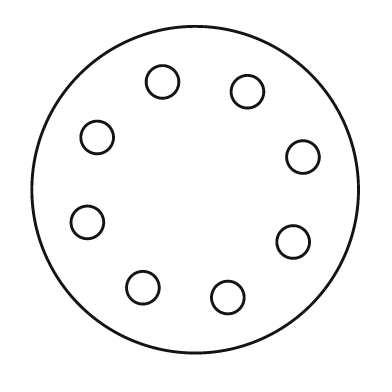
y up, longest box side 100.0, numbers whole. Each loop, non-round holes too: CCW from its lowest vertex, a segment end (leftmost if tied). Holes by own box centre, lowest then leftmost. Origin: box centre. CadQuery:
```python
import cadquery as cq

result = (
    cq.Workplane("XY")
    .moveTo(0.0, 0.0)
    .circle(50.0)
    .moveTo(10.0, -33.0)
    .circle(5.0)
    .moveTo(-16.0, -30.0)
    .circle(5.0)
    .moveTo(30.0, -16.0)
    .circle(5.0)
    .moveTo(-33.0, -10.0)
    .circle(5.0)
    .moveTo(33.0, 10.0)
    .circle(5.0)
    .moveTo(-30.0, 16.0)
    .circle(5.0)
    .moveTo(16.0, 30.0)
    .circle(5.0)
    .moveTo(-10.0, 33.0)
    .circle(5.0)
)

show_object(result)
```